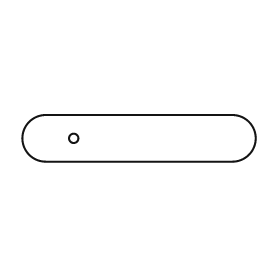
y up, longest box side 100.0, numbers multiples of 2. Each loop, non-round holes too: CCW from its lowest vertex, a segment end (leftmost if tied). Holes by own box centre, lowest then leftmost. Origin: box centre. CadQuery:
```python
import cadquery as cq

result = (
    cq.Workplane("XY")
    .moveTo(-40.0, -10.0)
    .lineTo(40.0, -10.0)
    .threePointArc((50.0, 0.0), (40.0, 10.0))
    .lineTo(-40.0, 10.0)
    .threePointArc((-50.0, 0.0), (-40.0, -10.0))
    .close()
    .moveTo(-28.0, 0.0)
    .circle(2.0)
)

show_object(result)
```